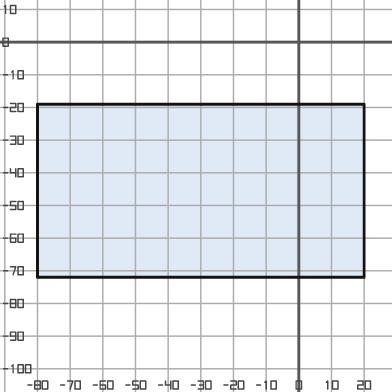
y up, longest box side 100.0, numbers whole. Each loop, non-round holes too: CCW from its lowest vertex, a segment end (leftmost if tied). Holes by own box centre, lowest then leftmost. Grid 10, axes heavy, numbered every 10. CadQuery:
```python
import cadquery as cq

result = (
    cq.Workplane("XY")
    .moveTo(-80.0, -72.0)
    .lineTo(20.0, -72.0)
    .lineTo(20.0, -19.0)
    .lineTo(-80.0, -19.0)
    .close()
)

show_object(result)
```